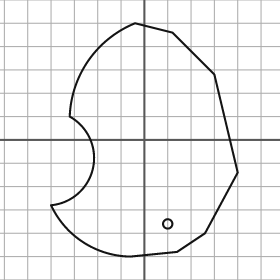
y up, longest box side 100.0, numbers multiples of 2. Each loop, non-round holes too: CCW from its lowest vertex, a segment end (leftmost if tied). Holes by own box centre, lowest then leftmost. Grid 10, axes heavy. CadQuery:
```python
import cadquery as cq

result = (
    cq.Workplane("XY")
    .moveTo(-6.0, -50.0)
    .lineTo(14.0, -48.0)
    .lineTo(26.0, -40.0)
    .lineTo(40.0, -14.0)
    .lineTo(30.0, 28.0)
    .lineTo(12.0, 46.0)
    .lineTo(-4.0, 50.0)
    .threePointArc((-24.0, 34.0), (-32.0, 10.0))
    .threePointArc((-22.0, -12.0), (-40.0, -28.0))
    .threePointArc((-26.0, -44.0), (-6.0, -50.0))
    .close()
    .moveTo(10.0, -36.0)
    .circle(2.0)
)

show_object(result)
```